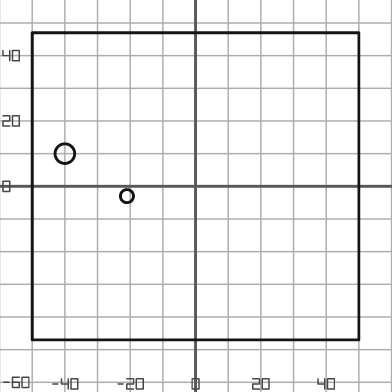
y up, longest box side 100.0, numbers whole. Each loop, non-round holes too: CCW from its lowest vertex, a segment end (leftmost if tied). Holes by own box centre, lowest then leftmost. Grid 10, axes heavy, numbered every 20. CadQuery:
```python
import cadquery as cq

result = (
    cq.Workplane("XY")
    .moveTo(-50.0, -47.0)
    .lineTo(50.0, -47.0)
    .lineTo(50.0, 47.0)
    .lineTo(-50.0, 47.0)
    .close()
    .moveTo(-21.0, -3.0)
    .circle(2.0)
    .moveTo(-40.0, 10.0)
    .circle(3.0)
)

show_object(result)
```